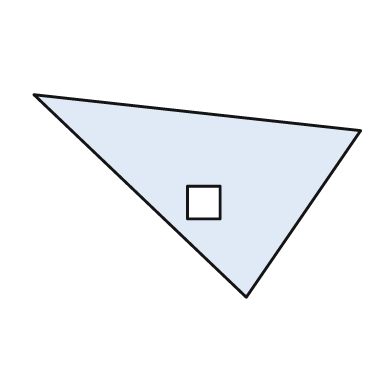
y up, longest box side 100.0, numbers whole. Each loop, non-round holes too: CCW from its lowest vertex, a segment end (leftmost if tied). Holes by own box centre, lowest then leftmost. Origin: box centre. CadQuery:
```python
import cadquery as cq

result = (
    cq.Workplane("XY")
    .moveTo(15.0, -31.0)
    .lineTo(50.0, 20.0)
    .lineTo(-50.0, 31.0)
    .close()
    .moveTo(-3.0, -7.0)
    .lineTo(7.0, -7.0)
    .lineTo(7.0, 3.0)
    .lineTo(-3.0, 3.0)
    .close()
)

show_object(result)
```